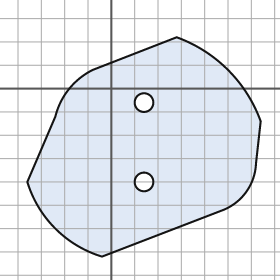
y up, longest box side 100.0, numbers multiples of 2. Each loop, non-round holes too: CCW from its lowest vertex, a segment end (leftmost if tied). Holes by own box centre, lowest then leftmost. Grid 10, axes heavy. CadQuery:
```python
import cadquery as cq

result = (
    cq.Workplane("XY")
    .moveTo(-4.0, -72.0)
    .lineTo(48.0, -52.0)
    .threePointArc((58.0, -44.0), (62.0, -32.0))
    .lineTo(64.0, -14.0)
    .threePointArc((50.0, 8.0), (28.0, 22.0))
    .lineTo(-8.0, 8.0)
    .threePointArc((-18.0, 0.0), (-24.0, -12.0))
    .lineTo(-36.0, -40.0)
    .threePointArc((-24.0, -60.0), (-4.0, -72.0))
    .close()
    .moveTo(14.0, -40.0)
    .circle(4.0)
    .moveTo(14.0, -6.0)
    .circle(4.0)
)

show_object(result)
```